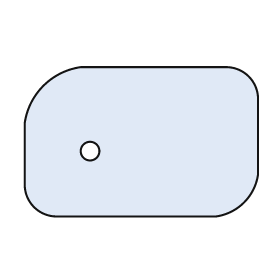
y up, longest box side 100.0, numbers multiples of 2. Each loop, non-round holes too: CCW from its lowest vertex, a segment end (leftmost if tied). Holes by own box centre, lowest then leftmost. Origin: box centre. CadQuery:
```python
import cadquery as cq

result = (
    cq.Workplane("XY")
    .moveTo(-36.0, -32.0)
    .lineTo(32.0, -32.0)
    .threePointArc((44.0, -26.0), (50.0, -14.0))
    .lineTo(50.0, 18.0)
    .threePointArc((46.0, 28.0), (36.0, 32.0))
    .lineTo(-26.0, 32.0)
    .threePointArc((-42.0, 24.0), (-50.0, 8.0))
    .lineTo(-50.0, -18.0)
    .threePointArc((-46.0, -28.0), (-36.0, -32.0))
    .close()
    .moveTo(-22.0, -4.0)
    .circle(4.0)
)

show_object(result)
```